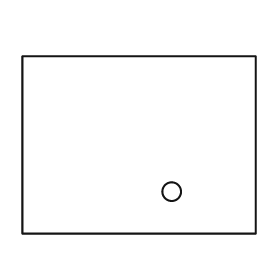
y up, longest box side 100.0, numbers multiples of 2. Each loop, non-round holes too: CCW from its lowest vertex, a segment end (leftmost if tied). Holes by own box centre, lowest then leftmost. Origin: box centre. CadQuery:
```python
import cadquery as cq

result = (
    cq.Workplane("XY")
    .moveTo(-50.0, -38.0)
    .lineTo(50.0, -38.0)
    .lineTo(50.0, 38.0)
    .lineTo(-50.0, 38.0)
    .close()
    .moveTo(14.0, -20.0)
    .circle(4.0)
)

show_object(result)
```